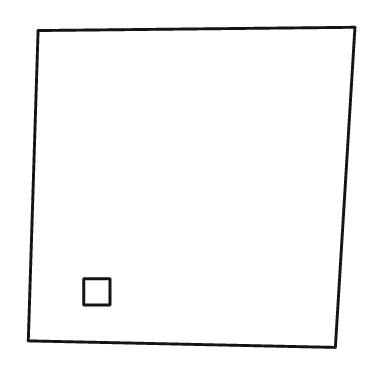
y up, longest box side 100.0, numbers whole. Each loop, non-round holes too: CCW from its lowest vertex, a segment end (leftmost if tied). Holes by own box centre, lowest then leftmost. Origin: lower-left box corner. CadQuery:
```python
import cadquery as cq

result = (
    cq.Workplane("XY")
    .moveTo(94.0, 0.0)
    .lineTo(100.0, 98.0)
    .lineTo(3.0, 97.0)
    .lineTo(0.0, 2.0)
    .close()
    .moveTo(17.0, 13.0)
    .lineTo(25.0, 13.0)
    .lineTo(25.0, 21.0)
    .lineTo(17.0, 21.0)
    .close()
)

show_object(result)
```